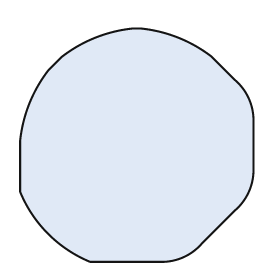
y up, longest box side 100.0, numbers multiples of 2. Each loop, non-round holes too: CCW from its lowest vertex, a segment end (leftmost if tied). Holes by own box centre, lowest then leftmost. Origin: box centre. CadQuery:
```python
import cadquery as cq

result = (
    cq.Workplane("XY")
    .moveTo(-20.0, -50.0)
    .lineTo(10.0, -50.0)
    .threePointArc((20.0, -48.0), (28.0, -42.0))
    .lineTo(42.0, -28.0)
    .threePointArc((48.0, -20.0), (50.0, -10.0))
    .lineTo(50.0, 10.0)
    .threePointArc((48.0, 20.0), (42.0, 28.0))
    .lineTo(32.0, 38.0)
    .threePointArc((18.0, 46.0), (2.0, 50.0))
    .lineTo(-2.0, 50.0)
    .threePointArc((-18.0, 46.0), (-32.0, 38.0))
    .lineTo(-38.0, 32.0)
    .threePointArc((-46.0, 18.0), (-50.0, 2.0))
    .lineTo(-50.0, -20.0)
    .threePointArc((-38.0, -38.0), (-20.0, -50.0))
    .close()
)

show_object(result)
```